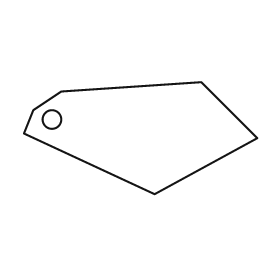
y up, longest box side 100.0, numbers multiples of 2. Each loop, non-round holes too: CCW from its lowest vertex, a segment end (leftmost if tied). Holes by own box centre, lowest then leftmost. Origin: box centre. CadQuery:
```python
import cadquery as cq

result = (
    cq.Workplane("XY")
    .moveTo(6.0, -24.0)
    .lineTo(50.0, 0.0)
    .lineTo(26.0, 24.0)
    .lineTo(-34.0, 20.0)
    .lineTo(-46.0, 12.0)
    .lineTo(-50.0, 2.0)
    .close()
    .moveTo(-38.0, 8.0)
    .circle(4.0)
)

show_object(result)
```